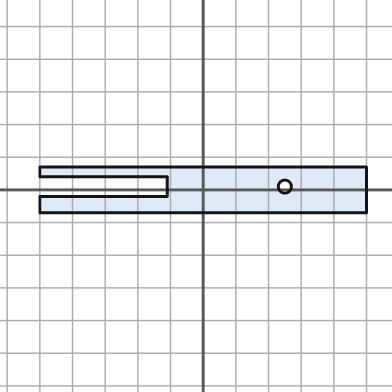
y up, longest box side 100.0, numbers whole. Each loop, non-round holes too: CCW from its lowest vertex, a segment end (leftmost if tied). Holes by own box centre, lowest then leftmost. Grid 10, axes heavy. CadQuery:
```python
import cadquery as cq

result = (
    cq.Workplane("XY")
    .moveTo(-50.0, -7.0)
    .lineTo(50.0, -7.0)
    .lineTo(50.0, 7.0)
    .lineTo(-50.0, 7.0)
    .lineTo(-50.0, 4.0)
    .lineTo(-11.0, 4.0)
    .lineTo(-11.0, -2.0)
    .lineTo(-50.0, -2.0)
    .close()
    .moveTo(25.0, 1.0)
    .circle(2.0)
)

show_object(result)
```